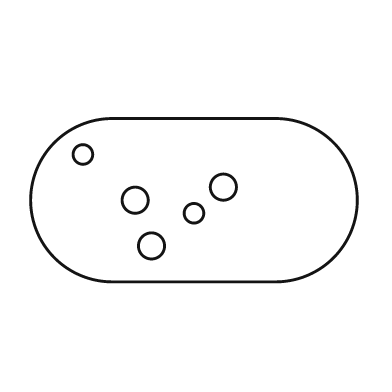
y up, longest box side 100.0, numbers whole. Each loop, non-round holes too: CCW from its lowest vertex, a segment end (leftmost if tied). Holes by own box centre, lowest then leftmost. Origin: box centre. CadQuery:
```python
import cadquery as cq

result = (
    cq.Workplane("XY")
    .moveTo(-25.0, -25.0)
    .lineTo(25.0, -25.0)
    .threePointArc((50.0, 0.0), (25.0, 25.0))
    .lineTo(-25.0, 25.0)
    .threePointArc((-50.0, 0.0), (-25.0, -25.0))
    .close()
    .moveTo(-13.0, -14.0)
    .circle(4.0)
    .moveTo(0.0, -4.0)
    .circle(3.0)
    .moveTo(-18.0, 0.0)
    .circle(4.0)
    .moveTo(9.0, 4.0)
    .circle(4.0)
    .moveTo(-34.0, 14.0)
    .circle(3.0)
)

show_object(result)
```